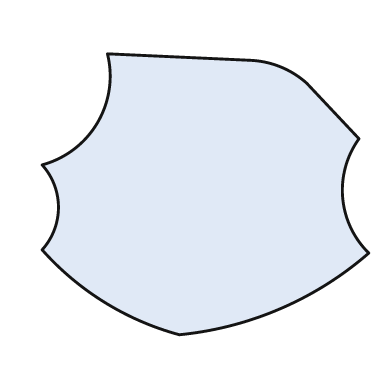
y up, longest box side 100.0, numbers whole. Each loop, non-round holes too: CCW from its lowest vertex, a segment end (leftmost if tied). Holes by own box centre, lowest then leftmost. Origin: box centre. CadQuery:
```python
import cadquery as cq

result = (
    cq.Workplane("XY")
    .moveTo(-8.0, -43.0)
    .threePointArc((23.0, -35.0), (50.0, -18.0))
    .threePointArc((42.0, -1.0), (47.0, 17.0))
    .lineTo(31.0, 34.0)
    .threePointArc((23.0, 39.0), (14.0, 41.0))
    .lineTo(-30.0, 43.0)
    .threePointArc((-33.0, 22.0), (-50.0, 9.0))
    .threePointArc((-45.0, -4.0), (-50.0, -17.0))
    .threePointArc((-31.0, -33.0), (-8.0, -43.0))
    .close()
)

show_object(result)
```